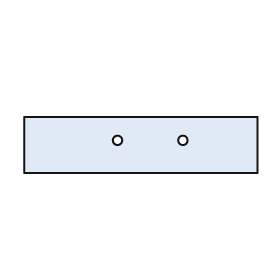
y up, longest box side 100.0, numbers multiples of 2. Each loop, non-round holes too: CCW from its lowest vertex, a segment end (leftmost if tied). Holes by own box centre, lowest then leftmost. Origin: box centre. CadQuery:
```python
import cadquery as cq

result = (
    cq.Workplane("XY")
    .moveTo(-50.0, -12.0)
    .lineTo(50.0, -12.0)
    .lineTo(50.0, 12.0)
    .lineTo(-50.0, 12.0)
    .close()
    .moveTo(-10.0, 2.0)
    .circle(2.0)
    .moveTo(18.0, 2.0)
    .circle(2.0)
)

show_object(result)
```